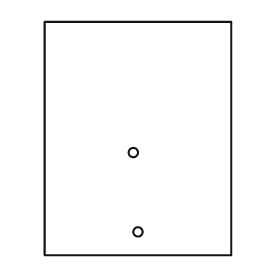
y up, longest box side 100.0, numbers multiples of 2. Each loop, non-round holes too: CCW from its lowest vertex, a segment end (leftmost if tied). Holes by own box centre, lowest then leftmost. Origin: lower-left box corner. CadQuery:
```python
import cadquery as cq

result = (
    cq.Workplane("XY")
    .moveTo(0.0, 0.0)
    .lineTo(80.0, 0.0)
    .lineTo(80.0, 100.0)
    .lineTo(0.0, 100.0)
    .close()
    .moveTo(40.0, 10.0)
    .circle(2.0)
    .moveTo(38.0, 44.0)
    .circle(2.0)
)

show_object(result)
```